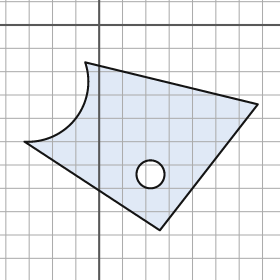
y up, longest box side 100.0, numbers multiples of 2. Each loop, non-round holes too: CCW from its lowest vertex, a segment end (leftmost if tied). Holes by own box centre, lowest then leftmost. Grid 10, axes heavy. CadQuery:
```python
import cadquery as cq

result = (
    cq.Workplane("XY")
    .moveTo(26.0, -88.0)
    .lineTo(68.0, -34.0)
    .lineTo(-6.0, -16.0)
    .threePointArc((-10.0, -40.0), (-32.0, -50.0))
    .close()
    .moveTo(22.0, -64.0)
    .circle(6.0)
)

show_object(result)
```